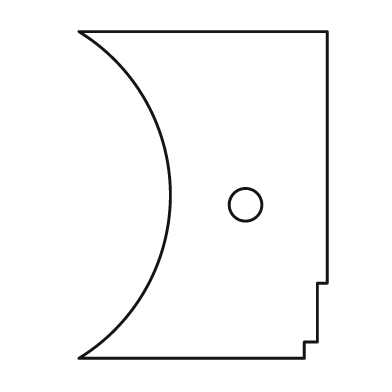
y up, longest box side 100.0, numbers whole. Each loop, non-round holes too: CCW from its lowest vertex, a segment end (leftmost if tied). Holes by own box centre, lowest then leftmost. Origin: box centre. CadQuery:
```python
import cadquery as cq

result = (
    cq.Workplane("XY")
    .moveTo(-38.0, -50.0)
    .lineTo(31.0, -50.0)
    .lineTo(31.0, -45.0)
    .lineTo(35.0, -45.0)
    .lineTo(35.0, -27.0)
    .lineTo(38.0, -27.0)
    .lineTo(38.0, 50.0)
    .lineTo(-38.0, 50.0)
    .threePointArc((-10.0, 0.0), (-38.0, -50.0))
    .close()
    .moveTo(13.0, -3.0)
    .circle(5.0)
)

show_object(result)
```